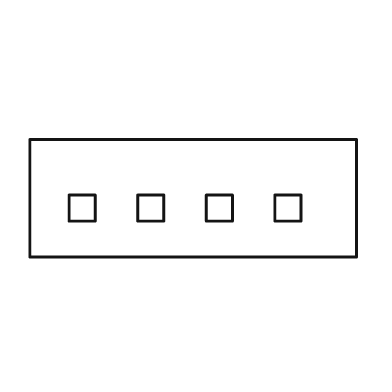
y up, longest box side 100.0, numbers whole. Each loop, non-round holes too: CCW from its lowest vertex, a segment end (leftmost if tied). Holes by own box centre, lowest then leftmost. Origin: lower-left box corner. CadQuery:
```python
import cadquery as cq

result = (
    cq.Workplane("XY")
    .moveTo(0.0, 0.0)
    .lineTo(100.0, 0.0)
    .lineTo(100.0, 36.0)
    .lineTo(0.0, 36.0)
    .close()
    .moveTo(12.0, 11.0)
    .lineTo(20.0, 11.0)
    .lineTo(20.0, 19.0)
    .lineTo(12.0, 19.0)
    .close()
    .moveTo(33.0, 11.0)
    .lineTo(41.0, 11.0)
    .lineTo(41.0, 19.0)
    .lineTo(33.0, 19.0)
    .close()
    .moveTo(54.0, 11.0)
    .lineTo(62.0, 11.0)
    .lineTo(62.0, 19.0)
    .lineTo(54.0, 19.0)
    .close()
    .moveTo(75.0, 11.0)
    .lineTo(83.0, 11.0)
    .lineTo(83.0, 19.0)
    .lineTo(75.0, 19.0)
    .close()
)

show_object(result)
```